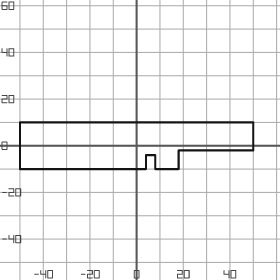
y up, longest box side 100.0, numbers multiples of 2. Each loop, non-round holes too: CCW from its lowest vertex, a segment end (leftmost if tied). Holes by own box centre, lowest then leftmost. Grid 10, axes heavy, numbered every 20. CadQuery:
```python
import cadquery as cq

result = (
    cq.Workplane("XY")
    .moveTo(-50.0, -10.0)
    .lineTo(4.0, -10.0)
    .lineTo(4.0, -4.0)
    .lineTo(8.0, -4.0)
    .lineTo(8.0, -10.0)
    .lineTo(18.0, -10.0)
    .lineTo(18.0, -2.0)
    .lineTo(50.0, -2.0)
    .lineTo(50.0, 10.0)
    .lineTo(-50.0, 10.0)
    .close()
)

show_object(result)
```